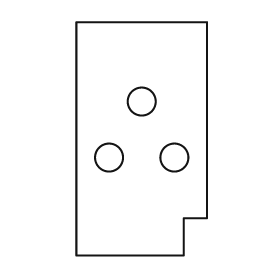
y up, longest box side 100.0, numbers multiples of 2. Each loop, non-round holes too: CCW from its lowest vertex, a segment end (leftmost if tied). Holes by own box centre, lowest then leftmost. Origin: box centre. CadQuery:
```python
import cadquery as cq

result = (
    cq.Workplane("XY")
    .moveTo(-28.0, -50.0)
    .lineTo(18.0, -50.0)
    .lineTo(18.0, -34.0)
    .lineTo(28.0, -34.0)
    .lineTo(28.0, 50.0)
    .lineTo(-28.0, 50.0)
    .close()
    .moveTo(-14.0, -8.0)
    .circle(6.0)
    .moveTo(14.0, -8.0)
    .circle(6.0)
    .moveTo(0.0, 16.0)
    .circle(6.0)
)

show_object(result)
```